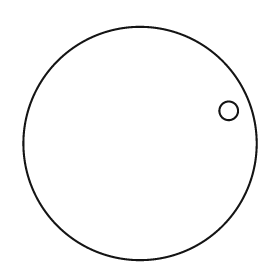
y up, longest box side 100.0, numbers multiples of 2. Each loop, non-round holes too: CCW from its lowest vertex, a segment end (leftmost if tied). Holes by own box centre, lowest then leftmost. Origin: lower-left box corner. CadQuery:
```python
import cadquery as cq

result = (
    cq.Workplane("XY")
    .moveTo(50.0, 50.0)
    .circle(50.0)
    .moveTo(88.0, 64.0)
    .circle(4.0)
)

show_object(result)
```